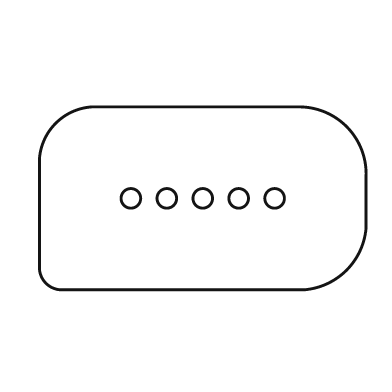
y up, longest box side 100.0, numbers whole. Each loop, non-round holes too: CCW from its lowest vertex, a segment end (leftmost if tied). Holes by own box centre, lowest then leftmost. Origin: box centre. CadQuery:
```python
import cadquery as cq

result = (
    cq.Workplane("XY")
    .moveTo(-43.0, -28.0)
    .lineTo(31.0, -28.0)
    .threePointArc((44.0, -22.0), (50.0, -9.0))
    .lineTo(50.0, 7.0)
    .threePointArc((44.0, 22.0), (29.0, 28.0))
    .lineTo(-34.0, 28.0)
    .threePointArc((-45.0, 23.0), (-50.0, 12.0))
    .lineTo(-50.0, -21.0)
    .threePointArc((-48.0, -26.0), (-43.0, -28.0))
    .close()
    .moveTo(-22.0, 0.0)
    .circle(3.0)
    .moveTo(-11.0, 0.0)
    .circle(3.0)
    .moveTo(0.0, 0.0)
    .circle(3.0)
    .moveTo(11.0, 0.0)
    .circle(3.0)
    .moveTo(22.0, 0.0)
    .circle(3.0)
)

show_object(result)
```